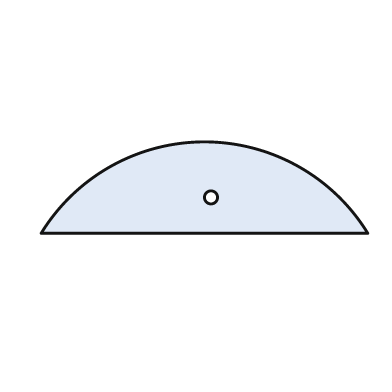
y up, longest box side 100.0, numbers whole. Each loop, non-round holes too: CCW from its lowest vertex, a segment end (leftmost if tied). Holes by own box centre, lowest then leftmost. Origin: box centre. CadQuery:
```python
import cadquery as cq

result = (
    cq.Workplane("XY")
    .moveTo(-50.0, -14.0)
    .lineTo(50.0, -14.0)
    .threePointArc((0.0, 14.0), (-50.0, -14.0))
    .close()
    .moveTo(2.0, -3.0)
    .circle(2.0)
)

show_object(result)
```